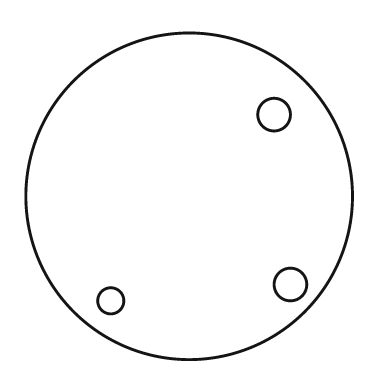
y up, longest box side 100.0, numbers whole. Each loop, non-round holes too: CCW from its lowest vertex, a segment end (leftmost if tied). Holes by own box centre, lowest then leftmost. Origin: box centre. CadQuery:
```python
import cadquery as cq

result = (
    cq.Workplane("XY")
    .moveTo(0.0, 0.0)
    .circle(50.0)
    .moveTo(-24.0, -32.0)
    .circle(4.0)
    .moveTo(31.0, -27.0)
    .circle(5.0)
    .moveTo(26.0, 25.0)
    .circle(5.0)
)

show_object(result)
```